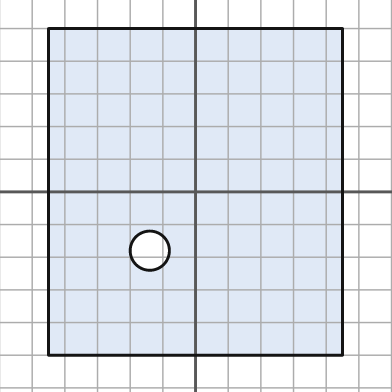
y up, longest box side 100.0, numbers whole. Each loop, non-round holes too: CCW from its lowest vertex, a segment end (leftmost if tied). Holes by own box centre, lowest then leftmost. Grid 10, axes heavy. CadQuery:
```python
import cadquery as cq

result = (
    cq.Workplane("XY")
    .moveTo(-45.0, -50.0)
    .lineTo(45.0, -50.0)
    .lineTo(45.0, 50.0)
    .lineTo(-45.0, 50.0)
    .close()
    .moveTo(-14.0, -18.0)
    .circle(6.0)
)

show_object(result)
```